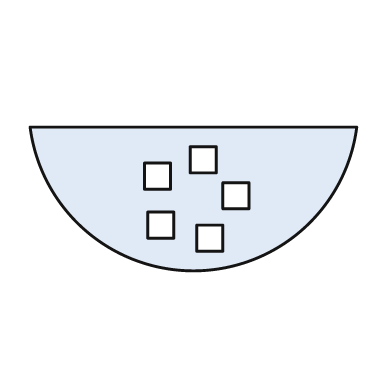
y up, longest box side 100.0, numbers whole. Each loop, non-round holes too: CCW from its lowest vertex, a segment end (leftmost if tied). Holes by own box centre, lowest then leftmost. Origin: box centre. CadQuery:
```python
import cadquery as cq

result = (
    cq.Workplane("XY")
    .moveTo(-50.0, 22.0)
    .threePointArc((0.0, -22.0), (50.0, 22.0))
    .close()
    .moveTo(1.0, -16.0)
    .lineTo(9.0, -16.0)
    .lineTo(9.0, -8.0)
    .lineTo(1.0, -8.0)
    .close()
    .moveTo(-14.0, -12.0)
    .lineTo(-6.0, -12.0)
    .lineTo(-6.0, -4.0)
    .lineTo(-14.0, -4.0)
    .close()
    .moveTo(9.0, -3.0)
    .lineTo(17.0, -3.0)
    .lineTo(17.0, 5.0)
    .lineTo(9.0, 5.0)
    .close()
    .moveTo(-15.0, 3.0)
    .lineTo(-7.0, 3.0)
    .lineTo(-7.0, 11.0)
    .lineTo(-15.0, 11.0)
    .close()
    .moveTo(-1.0, 8.0)
    .lineTo(7.0, 8.0)
    .lineTo(7.0, 16.0)
    .lineTo(-1.0, 16.0)
    .close()
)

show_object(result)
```